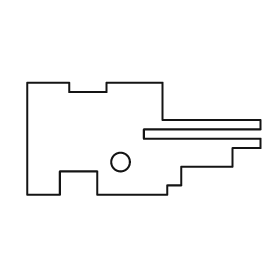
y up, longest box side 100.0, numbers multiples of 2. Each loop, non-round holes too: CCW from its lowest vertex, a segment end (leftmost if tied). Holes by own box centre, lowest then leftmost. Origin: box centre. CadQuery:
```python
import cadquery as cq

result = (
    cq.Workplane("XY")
    .moveTo(-50.0, -24.0)
    .lineTo(-36.0, -24.0)
    .lineTo(-36.0, -14.0)
    .lineTo(-20.0, -14.0)
    .lineTo(-20.0, -24.0)
    .lineTo(10.0, -24.0)
    .lineTo(10.0, -20.0)
    .lineTo(16.0, -20.0)
    .lineTo(16.0, -12.0)
    .lineTo(38.0, -12.0)
    .lineTo(38.0, -4.0)
    .lineTo(50.0, -4.0)
    .lineTo(50.0, 0.0)
    .lineTo(0.0, 0.0)
    .lineTo(0.0, 4.0)
    .lineTo(50.0, 4.0)
    .lineTo(50.0, 8.0)
    .lineTo(8.0, 8.0)
    .lineTo(8.0, 24.0)
    .lineTo(-16.0, 24.0)
    .lineTo(-16.0, 20.0)
    .lineTo(-32.0, 20.0)
    .lineTo(-32.0, 24.0)
    .lineTo(-50.0, 24.0)
    .close()
    .moveTo(-10.0, -10.0)
    .circle(4.0)
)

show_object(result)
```